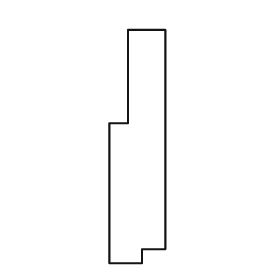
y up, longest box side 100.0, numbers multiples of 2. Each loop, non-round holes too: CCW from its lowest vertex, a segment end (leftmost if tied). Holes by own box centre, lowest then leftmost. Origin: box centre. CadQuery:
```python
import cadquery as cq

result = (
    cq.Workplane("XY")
    .moveTo(-12.0, -50.0)
    .lineTo(2.0, -50.0)
    .lineTo(2.0, -44.0)
    .lineTo(12.0, -44.0)
    .lineTo(12.0, 50.0)
    .lineTo(-4.0, 50.0)
    .lineTo(-4.0, 10.0)
    .lineTo(-12.0, 10.0)
    .close()
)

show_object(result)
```